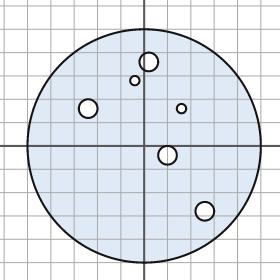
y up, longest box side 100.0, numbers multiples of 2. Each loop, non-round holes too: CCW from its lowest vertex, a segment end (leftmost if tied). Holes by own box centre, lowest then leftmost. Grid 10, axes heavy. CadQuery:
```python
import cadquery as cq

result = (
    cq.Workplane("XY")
    .moveTo(0.0, 0.0)
    .circle(50.0)
    .moveTo(26.0, -28.0)
    .circle(4.0)
    .moveTo(10.0, -4.0)
    .circle(4.0)
    .moveTo(-24.0, 16.0)
    .circle(4.0)
    .moveTo(16.0, 16.0)
    .circle(2.0)
    .moveTo(-4.0, 28.0)
    .circle(2.0)
    .moveTo(2.0, 36.0)
    .circle(4.0)
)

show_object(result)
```